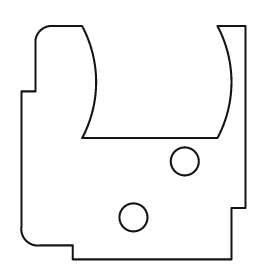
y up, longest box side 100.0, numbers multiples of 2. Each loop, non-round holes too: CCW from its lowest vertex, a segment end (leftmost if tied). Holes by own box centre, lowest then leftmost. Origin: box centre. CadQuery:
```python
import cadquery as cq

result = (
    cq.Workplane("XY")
    .moveTo(-26.0, -50.0)
    .lineTo(42.0, -50.0)
    .lineTo(42.0, -28.0)
    .lineTo(48.0, -28.0)
    .lineTo(48.0, 50.0)
    .lineTo(36.0, 50.0)
    .threePointArc((42.0, 26.0), (36.0, 2.0))
    .lineTo(-22.0, 2.0)
    .threePointArc((-16.0, 26.0), (-22.0, 50.0))
    .lineTo(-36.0, 50.0)
    .threePointArc((-40.0, 48.0), (-42.0, 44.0))
    .lineTo(-42.0, 22.0)
    .lineTo(-48.0, 22.0)
    .lineTo(-48.0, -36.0)
    .threePointArc((-46.0, -42.0), (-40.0, -44.0))
    .lineTo(-26.0, -44.0)
    .close()
    .moveTo(0.0, -32.0)
    .circle(6.0)
    .moveTo(22.0, -8.0)
    .circle(6.0)
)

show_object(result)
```